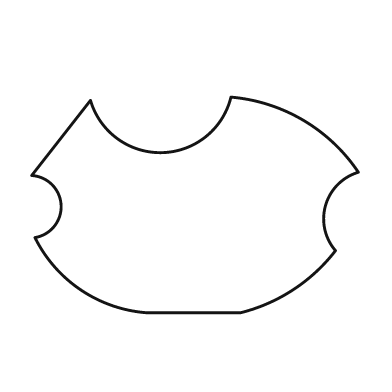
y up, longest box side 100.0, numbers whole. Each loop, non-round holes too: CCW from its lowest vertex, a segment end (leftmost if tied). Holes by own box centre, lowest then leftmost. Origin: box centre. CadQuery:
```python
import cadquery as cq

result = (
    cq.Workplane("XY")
    .moveTo(-15.0, -33.0)
    .lineTo(14.0, -33.0)
    .threePointArc((30.0, -26.0), (43.0, -14.0))
    .threePointArc((40.0, 0.0), (50.0, 10.0))
    .threePointArc((33.0, 26.0), (11.0, 33.0))
    .threePointArc((-10.0, 16.0), (-32.0, 32.0))
    .lineTo(-50.0, 9.0)
    .threePointArc((-41.0, 0.0), (-49.0, -10.0))
    .threePointArc((-35.0, -26.0), (-15.0, -33.0))
    .close()
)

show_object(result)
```